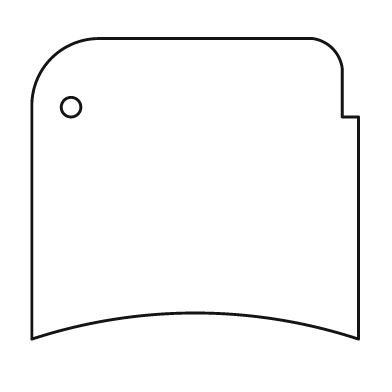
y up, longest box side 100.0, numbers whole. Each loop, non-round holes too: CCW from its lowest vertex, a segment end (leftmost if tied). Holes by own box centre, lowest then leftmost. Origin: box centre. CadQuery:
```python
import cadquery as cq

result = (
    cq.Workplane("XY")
    .moveTo(-50.0, -46.0)
    .threePointArc((0.0, -38.0), (50.0, -46.0))
    .lineTo(50.0, 22.0)
    .lineTo(45.0, 22.0)
    .lineTo(45.0, 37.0)
    .threePointArc((42.0, 43.0), (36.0, 46.0))
    .lineTo(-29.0, 46.0)
    .threePointArc((-44.0, 40.0), (-50.0, 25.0))
    .close()
    .moveTo(-38.0, 25.0)
    .circle(3.0)
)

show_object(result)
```